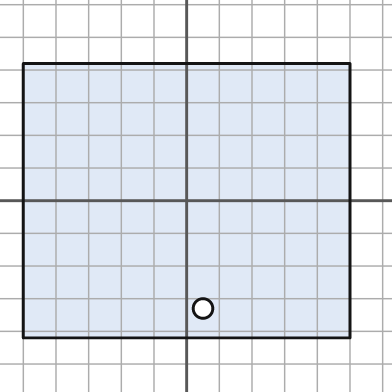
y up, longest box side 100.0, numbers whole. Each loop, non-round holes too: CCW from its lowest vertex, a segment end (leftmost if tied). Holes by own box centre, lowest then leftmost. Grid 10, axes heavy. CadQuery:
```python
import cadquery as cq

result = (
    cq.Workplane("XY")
    .moveTo(-50.0, -42.0)
    .lineTo(50.0, -42.0)
    .lineTo(50.0, 42.0)
    .lineTo(-50.0, 42.0)
    .close()
    .moveTo(5.0, -33.0)
    .circle(3.0)
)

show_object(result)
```